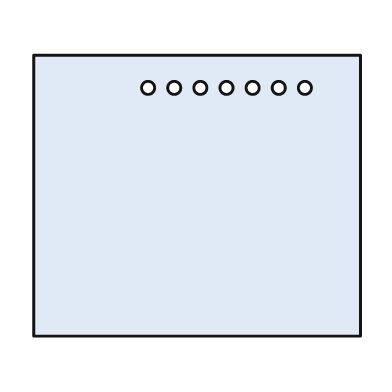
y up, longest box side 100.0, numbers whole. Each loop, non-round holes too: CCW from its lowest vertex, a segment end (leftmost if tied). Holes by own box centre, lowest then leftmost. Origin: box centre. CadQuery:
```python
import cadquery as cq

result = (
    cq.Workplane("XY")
    .moveTo(-50.0, -43.0)
    .lineTo(50.0, -43.0)
    .lineTo(50.0, 43.0)
    .lineTo(-50.0, 43.0)
    .close()
    .moveTo(-15.0, 33.0)
    .circle(2.0)
    .moveTo(-7.0, 33.0)
    .circle(2.0)
    .moveTo(1.0, 33.0)
    .circle(2.0)
    .moveTo(9.0, 33.0)
    .circle(2.0)
    .moveTo(17.0, 33.0)
    .circle(2.0)
    .moveTo(25.0, 33.0)
    .circle(2.0)
    .moveTo(33.0, 33.0)
    .circle(2.0)
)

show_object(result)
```